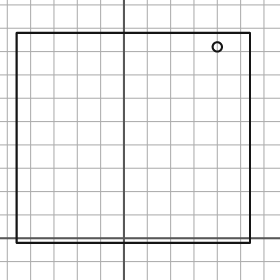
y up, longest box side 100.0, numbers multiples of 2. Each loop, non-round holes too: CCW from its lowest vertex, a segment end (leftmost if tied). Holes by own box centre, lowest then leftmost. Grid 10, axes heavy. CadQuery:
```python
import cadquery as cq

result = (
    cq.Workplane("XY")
    .moveTo(-46.0, -2.0)
    .lineTo(54.0, -2.0)
    .lineTo(54.0, 88.0)
    .lineTo(-46.0, 88.0)
    .close()
    .moveTo(40.0, 82.0)
    .circle(2.0)
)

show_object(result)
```